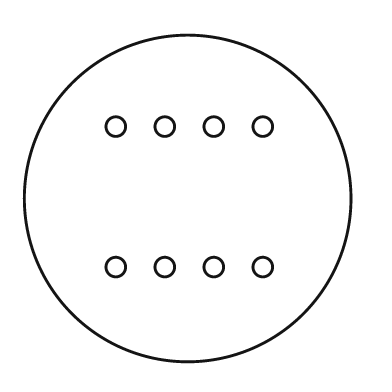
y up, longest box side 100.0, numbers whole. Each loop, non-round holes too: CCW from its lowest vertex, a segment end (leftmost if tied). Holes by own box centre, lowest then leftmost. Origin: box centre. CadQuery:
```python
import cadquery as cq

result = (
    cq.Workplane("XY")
    .moveTo(0.0, 0.0)
    .circle(50.0)
    .moveTo(-22.0, -21.0)
    .circle(3.0)
    .moveTo(-7.0, -21.0)
    .circle(3.0)
    .moveTo(8.0, -21.0)
    .circle(3.0)
    .moveTo(23.0, -21.0)
    .circle(3.0)
    .moveTo(-22.0, 22.0)
    .circle(3.0)
    .moveTo(-7.0, 22.0)
    .circle(3.0)
    .moveTo(8.0, 22.0)
    .circle(3.0)
    .moveTo(23.0, 22.0)
    .circle(3.0)
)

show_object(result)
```